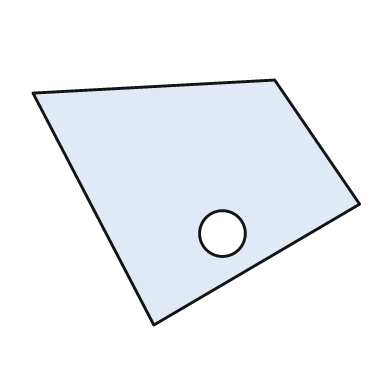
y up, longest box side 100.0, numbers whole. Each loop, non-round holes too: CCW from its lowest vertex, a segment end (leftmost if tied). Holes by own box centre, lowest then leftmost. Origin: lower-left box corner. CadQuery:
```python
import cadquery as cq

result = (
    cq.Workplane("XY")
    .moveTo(37.0, 0.0)
    .lineTo(100.0, 37.0)
    .lineTo(74.0, 75.0)
    .lineTo(0.0, 71.0)
    .close()
    .moveTo(58.0, 28.0)
    .circle(7.0)
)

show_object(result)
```